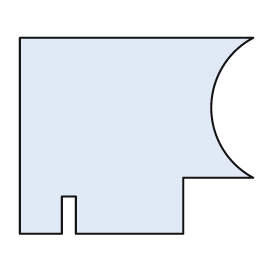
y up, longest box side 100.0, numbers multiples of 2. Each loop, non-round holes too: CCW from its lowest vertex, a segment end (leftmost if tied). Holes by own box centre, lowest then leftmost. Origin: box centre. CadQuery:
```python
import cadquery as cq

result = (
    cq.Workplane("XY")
    .moveTo(-50.0, -42.0)
    .lineTo(-32.0, -42.0)
    .lineTo(-32.0, -26.0)
    .lineTo(-26.0, -26.0)
    .lineTo(-26.0, -42.0)
    .lineTo(20.0, -42.0)
    .lineTo(20.0, -18.0)
    .lineTo(50.0, -18.0)
    .threePointArc((32.0, 12.0), (50.0, 42.0))
    .lineTo(-50.0, 42.0)
    .close()
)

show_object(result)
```